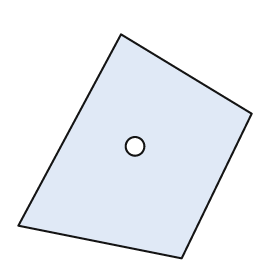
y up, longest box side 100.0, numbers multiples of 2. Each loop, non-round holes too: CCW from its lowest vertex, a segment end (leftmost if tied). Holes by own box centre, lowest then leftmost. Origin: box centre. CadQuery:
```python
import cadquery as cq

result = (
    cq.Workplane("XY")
    .moveTo(20.0, -48.0)
    .lineTo(50.0, 14.0)
    .lineTo(-6.0, 48.0)
    .lineTo(-50.0, -34.0)
    .close()
    .moveTo(0.0, 0.0)
    .circle(4.0)
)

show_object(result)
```